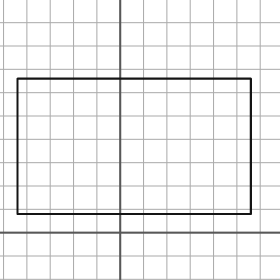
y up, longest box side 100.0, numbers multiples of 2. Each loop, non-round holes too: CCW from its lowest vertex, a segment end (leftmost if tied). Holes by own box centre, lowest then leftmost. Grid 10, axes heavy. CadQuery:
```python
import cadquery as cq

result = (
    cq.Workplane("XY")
    .moveTo(-44.0, 8.0)
    .lineTo(56.0, 8.0)
    .lineTo(56.0, 66.0)
    .lineTo(-44.0, 66.0)
    .close()
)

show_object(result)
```